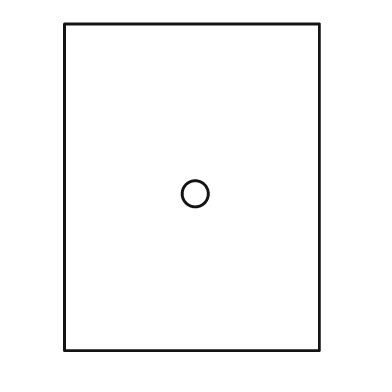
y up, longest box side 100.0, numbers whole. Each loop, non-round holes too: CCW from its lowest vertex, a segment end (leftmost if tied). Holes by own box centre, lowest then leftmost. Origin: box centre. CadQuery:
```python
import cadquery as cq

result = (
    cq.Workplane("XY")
    .moveTo(-39.0, -50.0)
    .lineTo(39.0, -50.0)
    .lineTo(39.0, 50.0)
    .lineTo(-39.0, 50.0)
    .close()
    .moveTo(1.0, -2.0)
    .circle(4.0)
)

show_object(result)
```